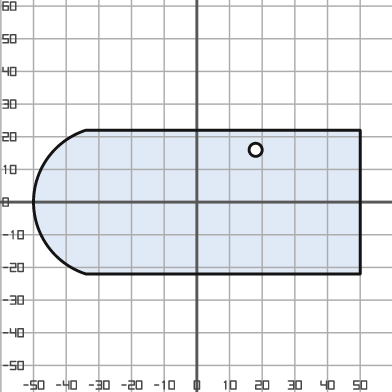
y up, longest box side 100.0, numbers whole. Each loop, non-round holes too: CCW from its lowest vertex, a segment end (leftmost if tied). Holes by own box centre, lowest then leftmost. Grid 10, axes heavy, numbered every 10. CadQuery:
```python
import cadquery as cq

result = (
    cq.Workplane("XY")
    .moveTo(-34.0, -22.0)
    .lineTo(50.0, -22.0)
    .lineTo(50.0, 22.0)
    .lineTo(-34.0, 22.0)
    .threePointArc((-50.0, 0.0), (-34.0, -22.0))
    .close()
    .moveTo(18.0, 16.0)
    .circle(2.0)
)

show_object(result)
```